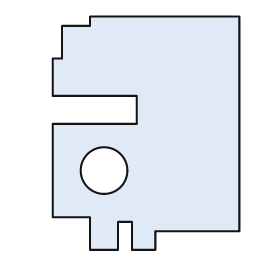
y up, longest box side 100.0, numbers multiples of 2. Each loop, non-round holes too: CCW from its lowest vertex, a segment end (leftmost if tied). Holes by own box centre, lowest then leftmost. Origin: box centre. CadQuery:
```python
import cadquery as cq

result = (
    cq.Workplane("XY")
    .moveTo(-24.0, -50.0)
    .lineTo(-12.0, -50.0)
    .lineTo(-12.0, -38.0)
    .lineTo(-6.0, -38.0)
    .lineTo(-6.0, -50.0)
    .lineTo(4.0, -50.0)
    .lineTo(4.0, -42.0)
    .lineTo(40.0, -42.0)
    .lineTo(40.0, 50.0)
    .lineTo(-24.0, 50.0)
    .lineTo(-24.0, 46.0)
    .lineTo(-36.0, 46.0)
    .lineTo(-36.0, 32.0)
    .lineTo(-40.0, 32.0)
    .lineTo(-40.0, 16.0)
    .lineTo(-4.0, 16.0)
    .lineTo(-4.0, 4.0)
    .lineTo(-40.0, 4.0)
    .lineTo(-40.0, -36.0)
    .lineTo(-24.0, -36.0)
    .close()
    .moveTo(-18.0, -16.0)
    .circle(10.0)
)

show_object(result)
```